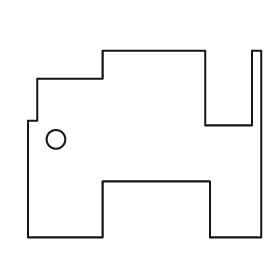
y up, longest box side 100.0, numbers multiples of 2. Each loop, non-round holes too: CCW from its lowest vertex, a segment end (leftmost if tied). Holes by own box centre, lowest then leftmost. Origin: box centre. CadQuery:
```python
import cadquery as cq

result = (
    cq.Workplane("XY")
    .moveTo(-50.0, -40.0)
    .lineTo(-18.0, -40.0)
    .lineTo(-18.0, -16.0)
    .lineTo(28.0, -16.0)
    .lineTo(28.0, -40.0)
    .lineTo(50.0, -40.0)
    .lineTo(50.0, 40.0)
    .lineTo(46.0, 40.0)
    .lineTo(46.0, 8.0)
    .lineTo(26.0, 8.0)
    .lineTo(26.0, 40.0)
    .lineTo(-18.0, 40.0)
    .lineTo(-18.0, 28.0)
    .lineTo(-46.0, 28.0)
    .lineTo(-46.0, 10.0)
    .lineTo(-50.0, 10.0)
    .close()
    .moveTo(-38.0, 2.0)
    .circle(4.0)
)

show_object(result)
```